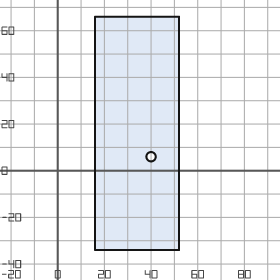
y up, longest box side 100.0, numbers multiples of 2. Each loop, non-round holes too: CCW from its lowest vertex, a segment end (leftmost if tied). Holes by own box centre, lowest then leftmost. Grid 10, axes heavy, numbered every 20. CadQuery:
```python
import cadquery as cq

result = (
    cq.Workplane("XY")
    .moveTo(16.0, -34.0)
    .lineTo(52.0, -34.0)
    .lineTo(52.0, 66.0)
    .lineTo(16.0, 66.0)
    .close()
    .moveTo(40.0, 6.0)
    .circle(2.0)
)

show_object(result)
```